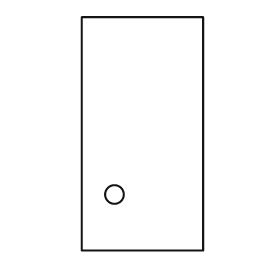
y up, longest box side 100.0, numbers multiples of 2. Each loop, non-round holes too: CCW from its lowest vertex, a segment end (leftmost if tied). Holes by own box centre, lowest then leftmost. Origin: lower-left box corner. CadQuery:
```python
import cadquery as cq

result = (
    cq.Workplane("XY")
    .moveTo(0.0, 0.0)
    .lineTo(52.0, 0.0)
    .lineTo(52.0, 100.0)
    .lineTo(0.0, 100.0)
    .close()
    .moveTo(14.0, 24.0)
    .circle(4.0)
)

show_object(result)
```